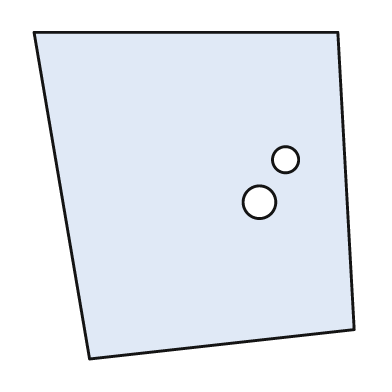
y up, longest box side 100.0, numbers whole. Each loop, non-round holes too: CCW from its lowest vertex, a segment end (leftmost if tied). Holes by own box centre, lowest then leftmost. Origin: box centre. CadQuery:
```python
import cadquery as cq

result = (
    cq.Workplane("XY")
    .moveTo(-32.0, -50.0)
    .lineTo(49.0, -41.0)
    .lineTo(44.0, 50.0)
    .lineTo(-49.0, 50.0)
    .close()
    .moveTo(20.0, -2.0)
    .circle(5.0)
    .moveTo(28.0, 11.0)
    .circle(4.0)
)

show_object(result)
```